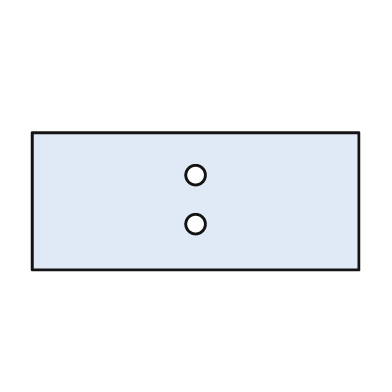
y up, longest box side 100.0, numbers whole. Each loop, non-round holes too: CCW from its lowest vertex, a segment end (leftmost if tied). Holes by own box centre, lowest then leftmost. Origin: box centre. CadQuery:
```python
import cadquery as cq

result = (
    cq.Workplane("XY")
    .moveTo(-50.0, -21.0)
    .lineTo(50.0, -21.0)
    .lineTo(50.0, 21.0)
    .lineTo(-50.0, 21.0)
    .close()
    .moveTo(0.0, -7.0)
    .circle(3.0)
    .moveTo(0.0, 8.0)
    .circle(3.0)
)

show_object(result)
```